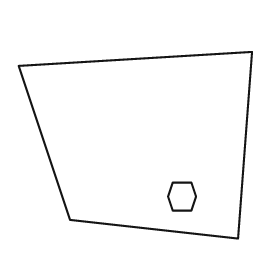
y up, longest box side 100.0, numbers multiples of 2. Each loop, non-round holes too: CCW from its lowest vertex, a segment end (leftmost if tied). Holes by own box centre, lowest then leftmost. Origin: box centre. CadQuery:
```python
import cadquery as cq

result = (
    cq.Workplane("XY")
    .moveTo(44.0, -40.0)
    .lineTo(50.0, 40.0)
    .lineTo(-50.0, 34.0)
    .lineTo(-28.0, -32.0)
    .close()
    .moveTo(16.0, -28.0)
    .lineTo(24.0, -28.0)
    .lineTo(26.0, -22.0)
    .lineTo(24.0, -16.0)
    .lineTo(16.0, -16.0)
    .lineTo(14.0, -22.0)
    .close()
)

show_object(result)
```